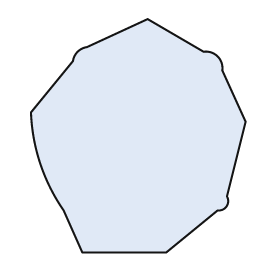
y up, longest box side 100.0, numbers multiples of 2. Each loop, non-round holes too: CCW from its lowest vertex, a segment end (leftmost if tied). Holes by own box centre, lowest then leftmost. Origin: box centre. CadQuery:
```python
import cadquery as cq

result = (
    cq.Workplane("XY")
    .moveTo(-24.0, -50.0)
    .lineTo(12.0, -50.0)
    .lineTo(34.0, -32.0)
    .threePointArc((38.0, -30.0), (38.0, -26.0))
    .lineTo(46.0, 6.0)
    .lineTo(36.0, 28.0)
    .threePointArc((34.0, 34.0), (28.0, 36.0))
    .lineTo(4.0, 50.0)
    .lineTo(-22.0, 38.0)
    .threePointArc((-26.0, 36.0), (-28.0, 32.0))
    .lineTo(-46.0, 10.0)
    .threePointArc((-42.0, -12.0), (-32.0, -32.0))
    .close()
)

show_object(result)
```